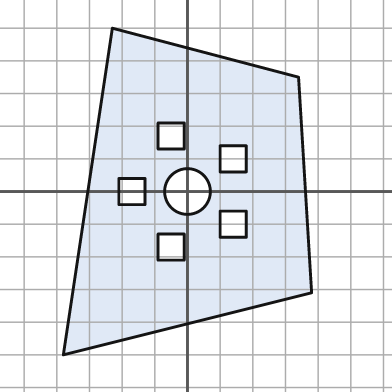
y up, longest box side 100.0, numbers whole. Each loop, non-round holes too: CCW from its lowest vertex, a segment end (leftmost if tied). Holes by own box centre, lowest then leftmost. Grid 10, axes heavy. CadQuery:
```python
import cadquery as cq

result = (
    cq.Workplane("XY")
    .moveTo(-38.0, -50.0)
    .lineTo(38.0, -31.0)
    .lineTo(34.0, 35.0)
    .lineTo(-23.0, 50.0)
    .close()
    .moveTo(-9.0, -21.0)
    .lineTo(-1.0, -21.0)
    .lineTo(-1.0, -13.0)
    .lineTo(-9.0, -13.0)
    .close()
    .moveTo(10.0, -14.0)
    .lineTo(18.0, -14.0)
    .lineTo(18.0, -6.0)
    .lineTo(10.0, -6.0)
    .close()
    .moveTo(-21.0, -4.0)
    .lineTo(-13.0, -4.0)
    .lineTo(-13.0, 4.0)
    .lineTo(-21.0, 4.0)
    .close()
    .moveTo(0.0, 0.0)
    .circle(7.0)
    .moveTo(10.0, 6.0)
    .lineTo(18.0, 6.0)
    .lineTo(18.0, 14.0)
    .lineTo(10.0, 14.0)
    .close()
    .moveTo(-9.0, 13.0)
    .lineTo(-1.0, 13.0)
    .lineTo(-1.0, 21.0)
    .lineTo(-9.0, 21.0)
    .close()
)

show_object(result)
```